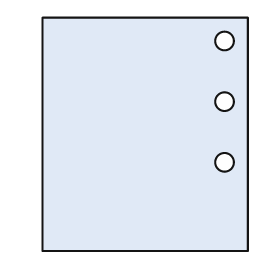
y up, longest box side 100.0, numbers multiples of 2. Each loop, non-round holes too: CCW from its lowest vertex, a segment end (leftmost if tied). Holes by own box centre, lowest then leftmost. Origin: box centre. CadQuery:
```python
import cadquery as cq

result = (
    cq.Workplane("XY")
    .moveTo(-44.0, -50.0)
    .lineTo(44.0, -50.0)
    .lineTo(44.0, 50.0)
    .lineTo(-44.0, 50.0)
    .close()
    .moveTo(34.0, -12.0)
    .circle(4.0)
    .moveTo(34.0, 14.0)
    .circle(4.0)
    .moveTo(34.0, 40.0)
    .circle(4.0)
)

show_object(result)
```